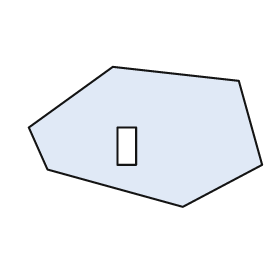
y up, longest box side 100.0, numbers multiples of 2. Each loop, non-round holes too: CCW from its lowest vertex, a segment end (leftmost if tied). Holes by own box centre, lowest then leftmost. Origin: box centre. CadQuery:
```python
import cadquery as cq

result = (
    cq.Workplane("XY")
    .moveTo(16.0, -30.0)
    .lineTo(50.0, -12.0)
    .lineTo(40.0, 24.0)
    .lineTo(-14.0, 30.0)
    .lineTo(-50.0, 4.0)
    .lineTo(-42.0, -14.0)
    .close()
    .moveTo(-12.0, -12.0)
    .lineTo(-4.0, -12.0)
    .lineTo(-4.0, 4.0)
    .lineTo(-12.0, 4.0)
    .close()
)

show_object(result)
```